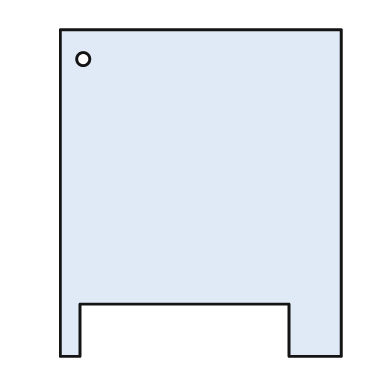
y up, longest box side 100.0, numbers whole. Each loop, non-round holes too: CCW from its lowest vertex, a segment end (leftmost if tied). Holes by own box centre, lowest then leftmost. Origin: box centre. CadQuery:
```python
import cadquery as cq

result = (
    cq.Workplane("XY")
    .moveTo(-43.0, -50.0)
    .lineTo(-37.0, -50.0)
    .lineTo(-37.0, -34.0)
    .lineTo(27.0, -34.0)
    .lineTo(27.0, -50.0)
    .lineTo(43.0, -50.0)
    .lineTo(43.0, 50.0)
    .lineTo(-43.0, 50.0)
    .close()
    .moveTo(-36.0, 41.0)
    .circle(2.0)
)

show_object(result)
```